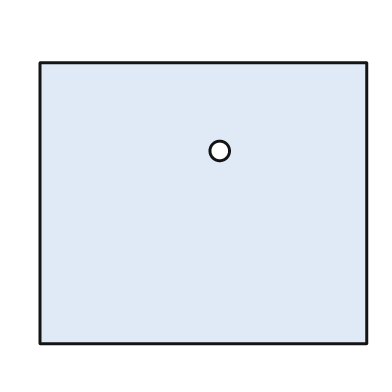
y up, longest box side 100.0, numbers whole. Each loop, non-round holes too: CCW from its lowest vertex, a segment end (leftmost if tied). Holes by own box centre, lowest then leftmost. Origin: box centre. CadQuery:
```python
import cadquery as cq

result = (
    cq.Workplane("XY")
    .moveTo(-50.0, -43.0)
    .lineTo(50.0, -43.0)
    .lineTo(50.0, 43.0)
    .lineTo(-50.0, 43.0)
    .close()
    .moveTo(5.0, 16.0)
    .circle(3.0)
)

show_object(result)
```